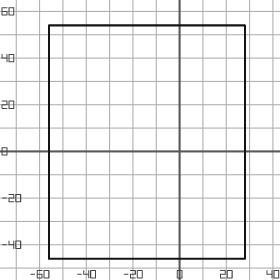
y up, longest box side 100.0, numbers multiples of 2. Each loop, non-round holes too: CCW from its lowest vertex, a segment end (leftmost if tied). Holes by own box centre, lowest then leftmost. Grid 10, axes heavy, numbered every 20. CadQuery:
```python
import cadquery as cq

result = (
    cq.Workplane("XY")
    .moveTo(-56.0, -46.0)
    .lineTo(28.0, -46.0)
    .lineTo(28.0, 54.0)
    .lineTo(-56.0, 54.0)
    .close()
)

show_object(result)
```